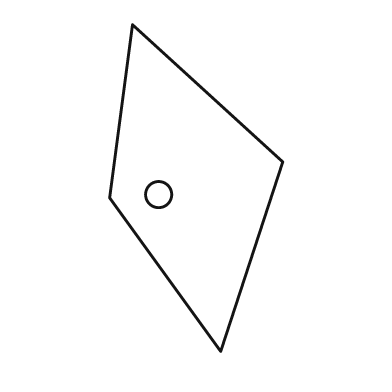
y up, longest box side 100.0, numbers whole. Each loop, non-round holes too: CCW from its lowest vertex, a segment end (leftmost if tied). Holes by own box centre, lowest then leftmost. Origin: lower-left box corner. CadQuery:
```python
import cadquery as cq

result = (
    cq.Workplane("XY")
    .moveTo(34.0, 0.0)
    .lineTo(53.0, 58.0)
    .lineTo(7.0, 100.0)
    .lineTo(0.0, 47.0)
    .close()
    .moveTo(15.0, 48.0)
    .circle(4.0)
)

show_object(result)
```